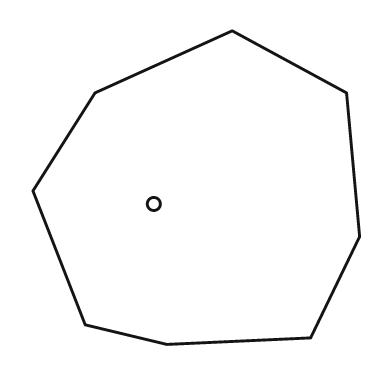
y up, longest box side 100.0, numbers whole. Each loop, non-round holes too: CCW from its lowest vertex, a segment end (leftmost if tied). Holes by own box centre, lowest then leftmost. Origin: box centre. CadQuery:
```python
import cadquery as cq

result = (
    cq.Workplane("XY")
    .moveTo(-9.0, -48.0)
    .lineTo(35.0, -46.0)
    .lineTo(50.0, -15.0)
    .lineTo(46.0, 29.0)
    .lineTo(11.0, 48.0)
    .lineTo(-31.0, 29.0)
    .lineTo(-50.0, -1.0)
    .lineTo(-34.0, -42.0)
    .close()
    .moveTo(-13.0, -5.0)
    .circle(2.0)
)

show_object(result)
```